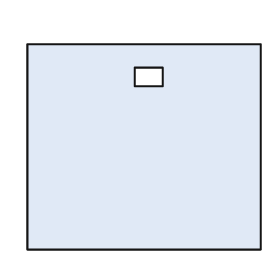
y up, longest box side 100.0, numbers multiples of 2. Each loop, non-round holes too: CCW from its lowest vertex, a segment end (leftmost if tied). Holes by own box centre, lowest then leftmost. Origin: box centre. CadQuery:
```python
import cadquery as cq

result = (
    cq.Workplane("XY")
    .moveTo(-50.0, -44.0)
    .lineTo(50.0, -44.0)
    .lineTo(50.0, 44.0)
    .lineTo(-50.0, 44.0)
    .close()
    .moveTo(-4.0, 26.0)
    .lineTo(8.0, 26.0)
    .lineTo(8.0, 34.0)
    .lineTo(-4.0, 34.0)
    .close()
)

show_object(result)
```